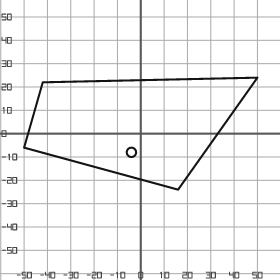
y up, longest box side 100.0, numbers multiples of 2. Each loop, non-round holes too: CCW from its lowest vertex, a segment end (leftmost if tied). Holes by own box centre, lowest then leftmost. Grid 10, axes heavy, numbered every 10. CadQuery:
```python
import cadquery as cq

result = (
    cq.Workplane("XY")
    .moveTo(16.0, -24.0)
    .lineTo(50.0, 24.0)
    .lineTo(-42.0, 22.0)
    .lineTo(-50.0, -6.0)
    .close()
    .moveTo(-4.0, -8.0)
    .circle(2.0)
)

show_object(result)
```